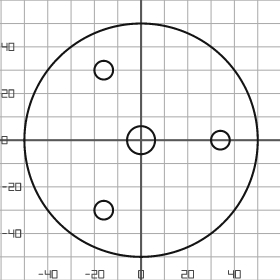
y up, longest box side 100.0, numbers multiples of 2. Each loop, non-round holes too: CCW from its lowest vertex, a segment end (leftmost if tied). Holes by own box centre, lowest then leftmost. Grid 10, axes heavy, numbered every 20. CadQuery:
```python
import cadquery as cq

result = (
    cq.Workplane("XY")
    .moveTo(0.0, 0.0)
    .circle(50.0)
    .moveTo(-16.0, -30.0)
    .circle(4.0)
    .moveTo(0.0, 0.0)
    .circle(6.0)
    .moveTo(34.0, 0.0)
    .circle(4.0)
    .moveTo(-16.0, 30.0)
    .circle(4.0)
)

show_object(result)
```